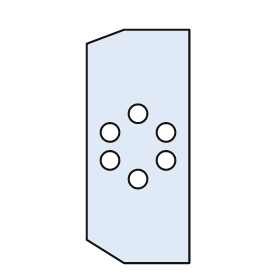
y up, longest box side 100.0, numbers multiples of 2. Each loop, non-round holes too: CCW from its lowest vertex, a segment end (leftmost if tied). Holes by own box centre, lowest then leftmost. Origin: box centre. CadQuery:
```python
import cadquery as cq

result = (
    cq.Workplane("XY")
    .moveTo(-6.0, -50.0)
    .lineTo(22.0, -50.0)
    .lineTo(22.0, 50.0)
    .lineTo(-6.0, 50.0)
    .lineTo(-22.0, 44.0)
    .lineTo(-22.0, -40.0)
    .close()
    .moveTo(0.0, -14.0)
    .circle(4.0)
    .moveTo(-12.0, -6.0)
    .circle(4.0)
    .moveTo(12.0, -6.0)
    .circle(4.0)
    .moveTo(-12.0, 6.0)
    .circle(4.0)
    .moveTo(12.0, 6.0)
    .circle(4.0)
    .moveTo(0.0, 14.0)
    .circle(4.0)
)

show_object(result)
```